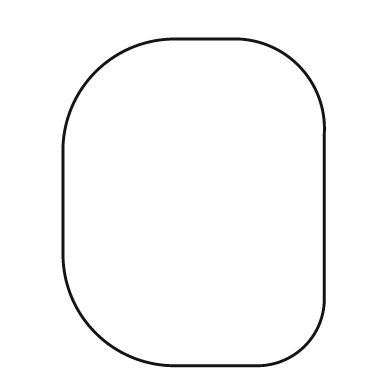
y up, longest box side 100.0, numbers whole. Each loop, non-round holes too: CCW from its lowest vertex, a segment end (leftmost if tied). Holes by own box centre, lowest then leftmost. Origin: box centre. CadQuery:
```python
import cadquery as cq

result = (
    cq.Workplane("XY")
    .moveTo(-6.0, -50.0)
    .lineTo(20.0, -50.0)
    .threePointArc((34.0, -44.0), (40.0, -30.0))
    .lineTo(40.0, 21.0)
    .threePointArc((32.0, 42.0), (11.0, 50.0))
    .lineTo(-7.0, 50.0)
    .threePointArc((-30.0, 40.0), (-40.0, 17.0))
    .lineTo(-40.0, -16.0)
    .threePointArc((-30.0, -40.0), (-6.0, -50.0))
    .close()
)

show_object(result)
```